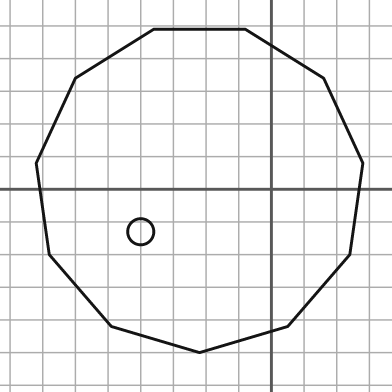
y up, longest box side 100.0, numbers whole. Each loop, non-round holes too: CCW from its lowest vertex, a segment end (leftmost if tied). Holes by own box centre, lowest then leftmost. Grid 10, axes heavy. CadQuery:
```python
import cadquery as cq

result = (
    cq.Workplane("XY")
    .moveTo(-22.0, -50.0)
    .lineTo(5.0, -42.0)
    .lineTo(24.0, -20.0)
    .lineTo(28.0, 8.0)
    .lineTo(16.0, 34.0)
    .lineTo(-8.0, 49.0)
    .lineTo(-36.0, 49.0)
    .lineTo(-60.0, 34.0)
    .lineTo(-72.0, 8.0)
    .lineTo(-68.0, -20.0)
    .lineTo(-49.0, -42.0)
    .close()
    .moveTo(-40.0, -13.0)
    .circle(4.0)
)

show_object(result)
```